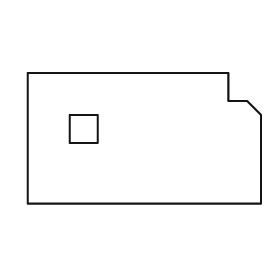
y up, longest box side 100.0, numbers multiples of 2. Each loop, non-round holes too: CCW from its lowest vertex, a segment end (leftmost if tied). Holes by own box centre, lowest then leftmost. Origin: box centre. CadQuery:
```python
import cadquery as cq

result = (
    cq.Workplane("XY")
    .moveTo(-50.0, -28.0)
    .lineTo(50.0, -28.0)
    .lineTo(50.0, 10.0)
    .lineTo(44.0, 16.0)
    .lineTo(36.0, 16.0)
    .lineTo(36.0, 28.0)
    .lineTo(-50.0, 28.0)
    .close()
    .moveTo(-32.0, -2.0)
    .lineTo(-20.0, -2.0)
    .lineTo(-20.0, 10.0)
    .lineTo(-32.0, 10.0)
    .close()
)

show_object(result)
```